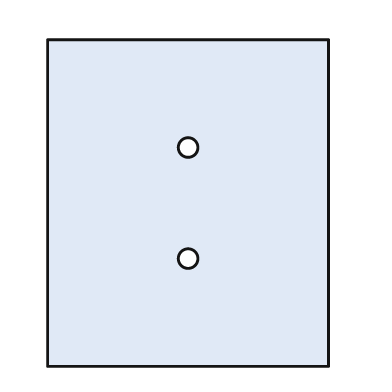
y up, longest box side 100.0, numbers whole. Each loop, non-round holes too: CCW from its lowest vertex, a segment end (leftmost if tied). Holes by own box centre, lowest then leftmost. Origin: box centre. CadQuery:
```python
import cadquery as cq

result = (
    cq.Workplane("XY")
    .moveTo(-43.0, -50.0)
    .lineTo(43.0, -50.0)
    .lineTo(43.0, 50.0)
    .lineTo(-43.0, 50.0)
    .close()
    .moveTo(0.0, -17.0)
    .circle(3.0)
    .moveTo(0.0, 17.0)
    .circle(3.0)
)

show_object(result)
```